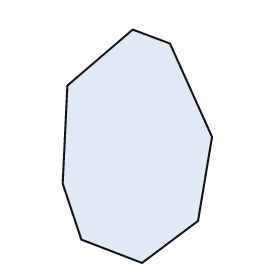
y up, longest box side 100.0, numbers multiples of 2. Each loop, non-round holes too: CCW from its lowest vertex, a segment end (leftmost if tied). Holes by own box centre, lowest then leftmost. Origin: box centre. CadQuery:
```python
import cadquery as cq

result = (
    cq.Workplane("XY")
    .moveTo(2.0, -50.0)
    .lineTo(26.0, -32.0)
    .lineTo(32.0, 4.0)
    .lineTo(14.0, 44.0)
    .lineTo(-2.0, 50.0)
    .lineTo(-30.0, 26.0)
    .lineTo(-32.0, -16.0)
    .lineTo(-24.0, -40.0)
    .close()
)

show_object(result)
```